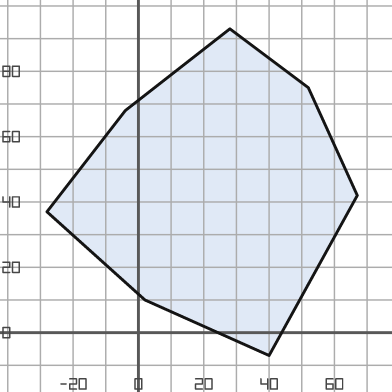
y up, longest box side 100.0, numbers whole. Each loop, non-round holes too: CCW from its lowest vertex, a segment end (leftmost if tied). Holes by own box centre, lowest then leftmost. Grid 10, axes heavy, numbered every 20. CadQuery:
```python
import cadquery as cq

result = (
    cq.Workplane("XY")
    .moveTo(40.0, -7.0)
    .lineTo(67.0, 42.0)
    .lineTo(52.0, 75.0)
    .lineTo(28.0, 93.0)
    .lineTo(-4.0, 68.0)
    .lineTo(-28.0, 37.0)
    .lineTo(2.0, 10.0)
    .close()
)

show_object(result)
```